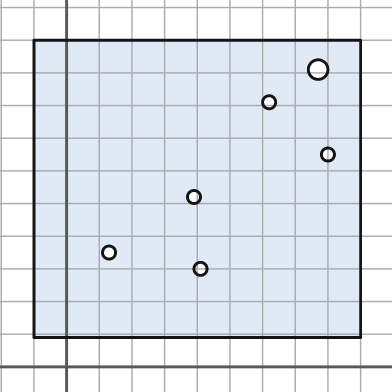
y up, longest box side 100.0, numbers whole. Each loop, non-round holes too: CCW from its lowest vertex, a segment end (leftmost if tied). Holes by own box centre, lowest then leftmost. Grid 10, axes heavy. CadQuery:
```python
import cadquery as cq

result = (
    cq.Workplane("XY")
    .moveTo(-10.0, 9.0)
    .lineTo(90.0, 9.0)
    .lineTo(90.0, 100.0)
    .lineTo(-10.0, 100.0)
    .close()
    .moveTo(41.0, 30.0)
    .circle(2.0)
    .moveTo(13.0, 35.0)
    .circle(2.0)
    .moveTo(39.0, 52.0)
    .circle(2.0)
    .moveTo(80.0, 65.0)
    .circle(2.0)
    .moveTo(62.0, 81.0)
    .circle(2.0)
    .moveTo(77.0, 91.0)
    .circle(3.0)
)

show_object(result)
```